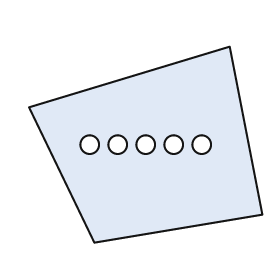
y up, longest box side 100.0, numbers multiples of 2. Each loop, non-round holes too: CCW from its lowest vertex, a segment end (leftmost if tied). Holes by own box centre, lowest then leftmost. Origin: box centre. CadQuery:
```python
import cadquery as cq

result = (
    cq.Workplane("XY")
    .moveTo(-22.0, -42.0)
    .lineTo(50.0, -30.0)
    .lineTo(36.0, 42.0)
    .lineTo(-50.0, 16.0)
    .close()
    .moveTo(-24.0, 0.0)
    .circle(4.0)
    .moveTo(-12.0, 0.0)
    .circle(4.0)
    .moveTo(0.0, 0.0)
    .circle(4.0)
    .moveTo(12.0, 0.0)
    .circle(4.0)
    .moveTo(24.0, 0.0)
    .circle(4.0)
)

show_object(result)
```